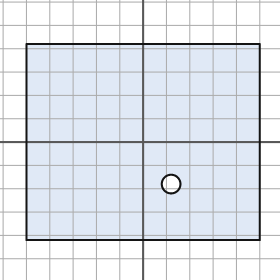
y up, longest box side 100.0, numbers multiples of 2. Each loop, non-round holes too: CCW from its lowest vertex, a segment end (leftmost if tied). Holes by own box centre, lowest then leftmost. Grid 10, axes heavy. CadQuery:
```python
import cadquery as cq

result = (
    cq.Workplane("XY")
    .moveTo(-50.0, -42.0)
    .lineTo(50.0, -42.0)
    .lineTo(50.0, 42.0)
    .lineTo(-50.0, 42.0)
    .close()
    .moveTo(12.0, -18.0)
    .circle(4.0)
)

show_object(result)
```